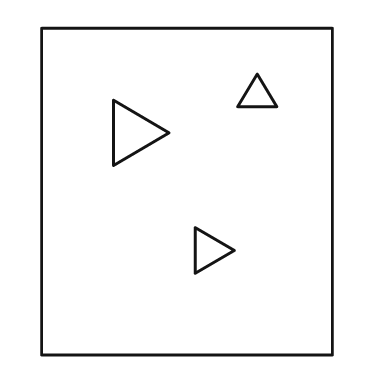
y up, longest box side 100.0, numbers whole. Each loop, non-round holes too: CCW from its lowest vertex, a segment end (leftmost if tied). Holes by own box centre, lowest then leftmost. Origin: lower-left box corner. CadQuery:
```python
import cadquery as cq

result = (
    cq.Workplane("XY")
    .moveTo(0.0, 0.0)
    .lineTo(89.0, 0.0)
    .lineTo(89.0, 100.0)
    .lineTo(0.0, 100.0)
    .close()
    .moveTo(47.0, 25.0)
    .lineTo(59.0, 32.0)
    .lineTo(47.0, 39.0)
    .close()
    .moveTo(22.0, 58.0)
    .lineTo(39.0, 68.0)
    .lineTo(22.0, 78.0)
    .close()
    .moveTo(60.0, 76.0)
    .lineTo(72.0, 76.0)
    .lineTo(66.0, 86.0)
    .close()
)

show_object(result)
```